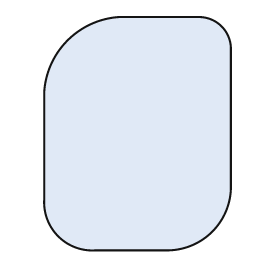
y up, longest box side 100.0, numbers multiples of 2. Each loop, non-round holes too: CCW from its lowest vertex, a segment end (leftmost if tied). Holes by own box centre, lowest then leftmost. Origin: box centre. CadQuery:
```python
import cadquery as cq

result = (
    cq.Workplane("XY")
    .moveTo(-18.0, -50.0)
    .lineTo(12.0, -50.0)
    .threePointArc((32.0, -42.0), (40.0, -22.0))
    .lineTo(40.0, 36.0)
    .threePointArc((36.0, 46.0), (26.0, 50.0))
    .lineTo(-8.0, 50.0)
    .threePointArc((-30.0, 40.0), (-40.0, 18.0))
    .lineTo(-40.0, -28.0)
    .threePointArc((-34.0, -44.0), (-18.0, -50.0))
    .close()
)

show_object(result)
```